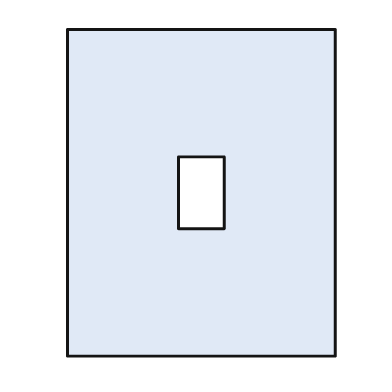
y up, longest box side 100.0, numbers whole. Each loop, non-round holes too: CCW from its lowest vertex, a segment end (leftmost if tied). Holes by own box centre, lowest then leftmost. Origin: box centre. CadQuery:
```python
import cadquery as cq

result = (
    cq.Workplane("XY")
    .moveTo(-41.0, -50.0)
    .lineTo(41.0, -50.0)
    .lineTo(41.0, 50.0)
    .lineTo(-41.0, 50.0)
    .close()
    .moveTo(-7.0, -11.0)
    .lineTo(7.0, -11.0)
    .lineTo(7.0, 11.0)
    .lineTo(-7.0, 11.0)
    .close()
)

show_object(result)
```